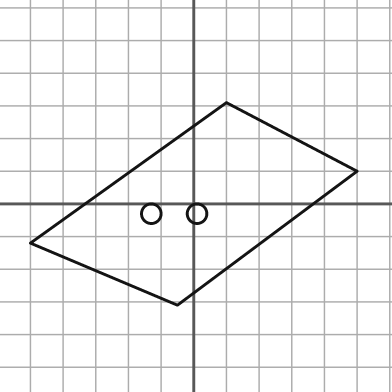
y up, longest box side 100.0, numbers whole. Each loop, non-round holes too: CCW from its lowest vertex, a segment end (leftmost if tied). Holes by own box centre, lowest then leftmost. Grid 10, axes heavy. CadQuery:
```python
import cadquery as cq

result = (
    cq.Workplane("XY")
    .moveTo(-5.0, -31.0)
    .lineTo(50.0, 10.0)
    .lineTo(10.0, 31.0)
    .lineTo(-50.0, -12.0)
    .close()
    .moveTo(-13.0, -3.0)
    .circle(3.0)
    .moveTo(1.0, -3.0)
    .circle(3.0)
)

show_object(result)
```